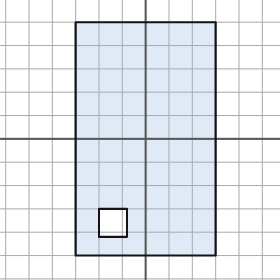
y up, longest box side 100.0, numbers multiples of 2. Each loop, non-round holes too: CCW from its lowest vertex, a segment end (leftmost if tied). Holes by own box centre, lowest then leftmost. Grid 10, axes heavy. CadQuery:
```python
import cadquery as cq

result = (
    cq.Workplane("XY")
    .moveTo(-30.0, -50.0)
    .lineTo(30.0, -50.0)
    .lineTo(30.0, 50.0)
    .lineTo(-30.0, 50.0)
    .close()
    .moveTo(-20.0, -42.0)
    .lineTo(-8.0, -42.0)
    .lineTo(-8.0, -30.0)
    .lineTo(-20.0, -30.0)
    .close()
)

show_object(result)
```